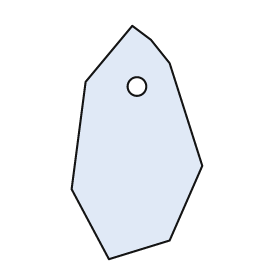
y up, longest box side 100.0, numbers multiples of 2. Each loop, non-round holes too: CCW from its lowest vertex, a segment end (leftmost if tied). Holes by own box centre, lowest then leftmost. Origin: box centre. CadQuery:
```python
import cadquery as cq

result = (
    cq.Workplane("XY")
    .moveTo(-12.0, -50.0)
    .lineTo(14.0, -42.0)
    .lineTo(28.0, -10.0)
    .lineTo(14.0, 34.0)
    .lineTo(6.0, 44.0)
    .lineTo(-2.0, 50.0)
    .lineTo(-22.0, 26.0)
    .lineTo(-28.0, -20.0)
    .close()
    .moveTo(0.0, 24.0)
    .circle(4.0)
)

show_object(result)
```